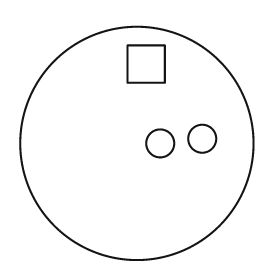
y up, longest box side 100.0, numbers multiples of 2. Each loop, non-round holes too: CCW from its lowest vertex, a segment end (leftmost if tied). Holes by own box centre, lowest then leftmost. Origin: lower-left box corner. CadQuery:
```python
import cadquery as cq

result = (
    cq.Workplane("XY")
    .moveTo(50.0, 50.0)
    .circle(50.0)
    .moveTo(60.0, 50.0)
    .circle(6.0)
    .moveTo(78.0, 52.0)
    .circle(6.0)
    .moveTo(46.0, 76.0)
    .lineTo(62.0, 76.0)
    .lineTo(62.0, 92.0)
    .lineTo(46.0, 92.0)
    .close()
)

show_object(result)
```